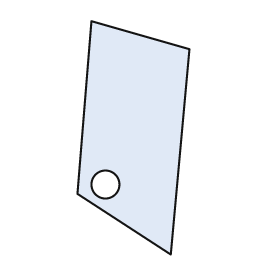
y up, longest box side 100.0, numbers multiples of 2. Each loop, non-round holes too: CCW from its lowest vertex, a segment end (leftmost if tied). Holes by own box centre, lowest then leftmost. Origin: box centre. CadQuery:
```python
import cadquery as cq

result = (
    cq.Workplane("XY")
    .moveTo(16.0, -50.0)
    .lineTo(24.0, 38.0)
    .lineTo(-18.0, 50.0)
    .lineTo(-24.0, -24.0)
    .close()
    .moveTo(-12.0, -20.0)
    .circle(6.0)
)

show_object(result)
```